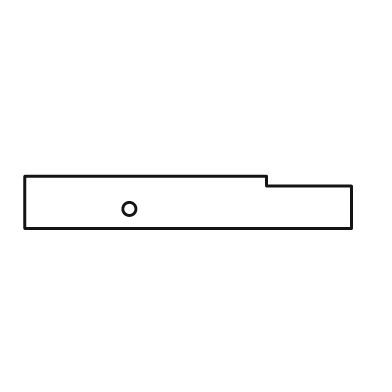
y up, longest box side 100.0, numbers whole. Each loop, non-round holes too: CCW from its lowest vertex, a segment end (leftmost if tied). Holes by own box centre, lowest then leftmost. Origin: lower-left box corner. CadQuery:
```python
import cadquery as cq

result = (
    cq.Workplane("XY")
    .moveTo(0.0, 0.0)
    .lineTo(100.0, 0.0)
    .lineTo(100.0, 13.0)
    .lineTo(74.0, 13.0)
    .lineTo(74.0, 16.0)
    .lineTo(0.0, 16.0)
    .close()
    .moveTo(32.0, 6.0)
    .circle(2.0)
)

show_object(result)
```